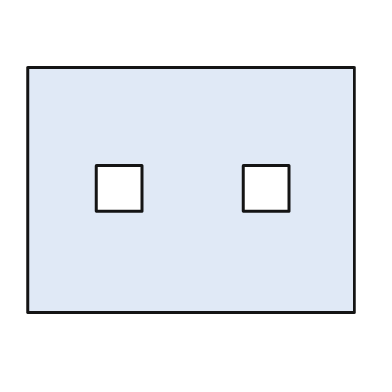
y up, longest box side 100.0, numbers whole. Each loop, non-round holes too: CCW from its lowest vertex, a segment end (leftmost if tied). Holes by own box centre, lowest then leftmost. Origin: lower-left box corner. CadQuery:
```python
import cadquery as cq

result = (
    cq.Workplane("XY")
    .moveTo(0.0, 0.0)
    .lineTo(100.0, 0.0)
    .lineTo(100.0, 75.0)
    .lineTo(0.0, 75.0)
    .close()
    .moveTo(21.0, 31.0)
    .lineTo(35.0, 31.0)
    .lineTo(35.0, 45.0)
    .lineTo(21.0, 45.0)
    .close()
    .moveTo(66.0, 31.0)
    .lineTo(80.0, 31.0)
    .lineTo(80.0, 45.0)
    .lineTo(66.0, 45.0)
    .close()
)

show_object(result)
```